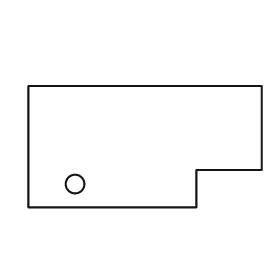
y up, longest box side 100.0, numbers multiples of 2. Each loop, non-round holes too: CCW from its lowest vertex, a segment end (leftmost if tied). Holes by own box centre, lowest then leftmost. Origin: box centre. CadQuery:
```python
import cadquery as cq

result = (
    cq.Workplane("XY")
    .moveTo(-50.0, -26.0)
    .lineTo(22.0, -26.0)
    .lineTo(22.0, -10.0)
    .lineTo(50.0, -10.0)
    .lineTo(50.0, 26.0)
    .lineTo(-50.0, 26.0)
    .close()
    .moveTo(-30.0, -16.0)
    .circle(4.0)
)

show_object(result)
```